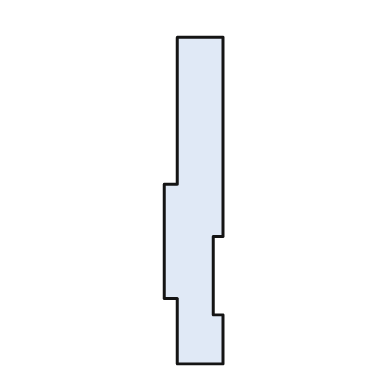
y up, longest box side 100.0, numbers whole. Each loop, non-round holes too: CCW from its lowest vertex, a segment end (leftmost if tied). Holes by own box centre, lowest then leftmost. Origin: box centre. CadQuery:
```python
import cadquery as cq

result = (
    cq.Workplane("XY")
    .moveTo(-5.0, -50.0)
    .lineTo(9.0, -50.0)
    .lineTo(9.0, -35.0)
    .lineTo(6.0, -35.0)
    .lineTo(6.0, -11.0)
    .lineTo(9.0, -11.0)
    .lineTo(9.0, 50.0)
    .lineTo(-5.0, 50.0)
    .lineTo(-5.0, 5.0)
    .lineTo(-9.0, 5.0)
    .lineTo(-9.0, -30.0)
    .lineTo(-5.0, -30.0)
    .close()
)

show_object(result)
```